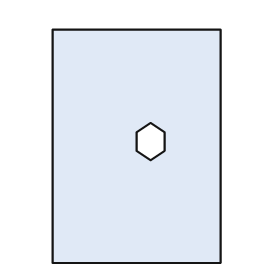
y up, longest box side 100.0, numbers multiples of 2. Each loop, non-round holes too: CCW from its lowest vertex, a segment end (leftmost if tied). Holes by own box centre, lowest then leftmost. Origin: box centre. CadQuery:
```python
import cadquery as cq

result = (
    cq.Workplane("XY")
    .moveTo(-36.0, -50.0)
    .lineTo(36.0, -50.0)
    .lineTo(36.0, 50.0)
    .lineTo(-36.0, 50.0)
    .close()
    .moveTo(6.0, -6.0)
    .lineTo(12.0, -2.0)
    .lineTo(12.0, 6.0)
    .lineTo(6.0, 10.0)
    .lineTo(0.0, 6.0)
    .lineTo(0.0, -2.0)
    .close()
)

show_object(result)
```